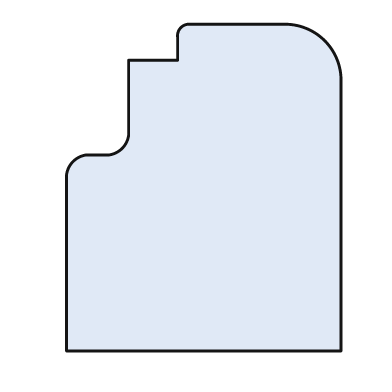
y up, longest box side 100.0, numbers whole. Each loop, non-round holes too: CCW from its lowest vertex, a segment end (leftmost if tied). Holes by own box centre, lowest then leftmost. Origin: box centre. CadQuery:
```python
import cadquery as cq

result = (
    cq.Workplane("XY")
    .moveTo(-42.0, -50.0)
    .lineTo(42.0, -50.0)
    .lineTo(42.0, 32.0)
    .threePointArc((37.0, 45.0), (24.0, 50.0))
    .lineTo(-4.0, 50.0)
    .threePointArc((-7.0, 49.0), (-8.0, 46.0))
    .lineTo(-8.0, 39.0)
    .lineTo(-23.0, 39.0)
    .lineTo(-23.0, 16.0)
    .threePointArc((-25.0, 12.0), (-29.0, 10.0))
    .lineTo(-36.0, 10.0)
    .threePointArc((-40.0, 8.0), (-42.0, 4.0))
    .close()
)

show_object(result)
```